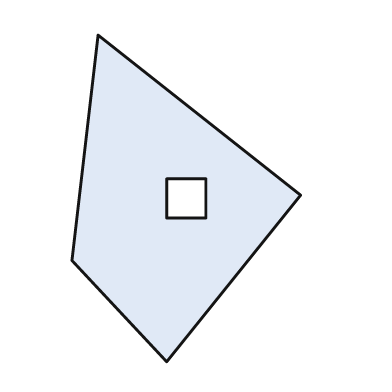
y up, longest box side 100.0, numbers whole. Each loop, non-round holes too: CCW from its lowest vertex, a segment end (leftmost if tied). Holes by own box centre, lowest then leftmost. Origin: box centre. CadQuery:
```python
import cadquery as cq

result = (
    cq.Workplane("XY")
    .moveTo(-6.0, -50.0)
    .lineTo(35.0, 1.0)
    .lineTo(-27.0, 50.0)
    .lineTo(-35.0, -19.0)
    .close()
    .moveTo(-6.0, -6.0)
    .lineTo(6.0, -6.0)
    .lineTo(6.0, 6.0)
    .lineTo(-6.0, 6.0)
    .close()
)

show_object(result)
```